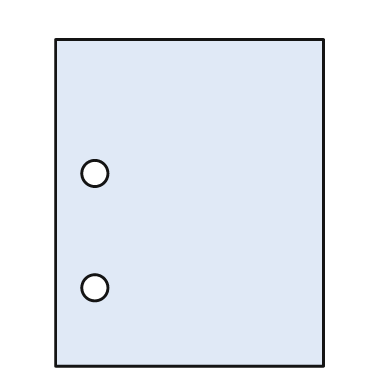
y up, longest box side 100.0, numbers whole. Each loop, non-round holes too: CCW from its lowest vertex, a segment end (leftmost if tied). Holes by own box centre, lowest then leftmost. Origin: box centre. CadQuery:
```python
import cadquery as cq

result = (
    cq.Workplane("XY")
    .moveTo(-41.0, -50.0)
    .lineTo(41.0, -50.0)
    .lineTo(41.0, 50.0)
    .lineTo(-41.0, 50.0)
    .close()
    .moveTo(-29.0, -26.0)
    .circle(4.0)
    .moveTo(-29.0, 9.0)
    .circle(4.0)
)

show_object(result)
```